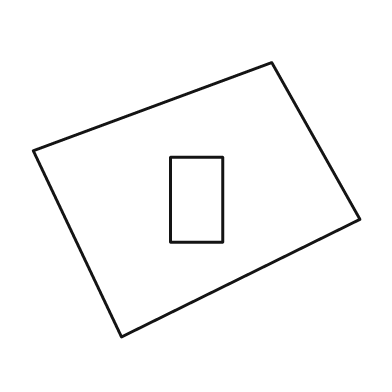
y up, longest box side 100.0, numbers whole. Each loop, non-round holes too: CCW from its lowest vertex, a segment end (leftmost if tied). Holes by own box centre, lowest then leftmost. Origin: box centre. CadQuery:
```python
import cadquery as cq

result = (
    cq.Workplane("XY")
    .moveTo(-23.0, -42.0)
    .lineTo(50.0, -6.0)
    .lineTo(23.0, 42.0)
    .lineTo(-50.0, 15.0)
    .close()
    .moveTo(-8.0, -13.0)
    .lineTo(8.0, -13.0)
    .lineTo(8.0, 13.0)
    .lineTo(-8.0, 13.0)
    .close()
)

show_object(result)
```